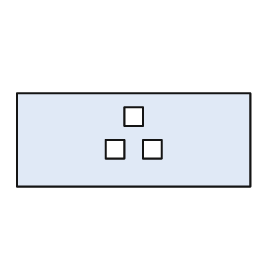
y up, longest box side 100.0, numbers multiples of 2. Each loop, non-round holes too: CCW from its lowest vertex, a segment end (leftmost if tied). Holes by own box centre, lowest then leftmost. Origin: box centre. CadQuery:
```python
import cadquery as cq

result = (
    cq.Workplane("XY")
    .moveTo(-50.0, -20.0)
    .lineTo(50.0, -20.0)
    .lineTo(50.0, 20.0)
    .lineTo(-50.0, 20.0)
    .close()
    .moveTo(-12.0, -8.0)
    .lineTo(-4.0, -8.0)
    .lineTo(-4.0, 0.0)
    .lineTo(-12.0, 0.0)
    .close()
    .moveTo(4.0, -8.0)
    .lineTo(12.0, -8.0)
    .lineTo(12.0, 0.0)
    .lineTo(4.0, 0.0)
    .close()
    .moveTo(-4.0, 6.0)
    .lineTo(4.0, 6.0)
    .lineTo(4.0, 14.0)
    .lineTo(-4.0, 14.0)
    .close()
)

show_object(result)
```